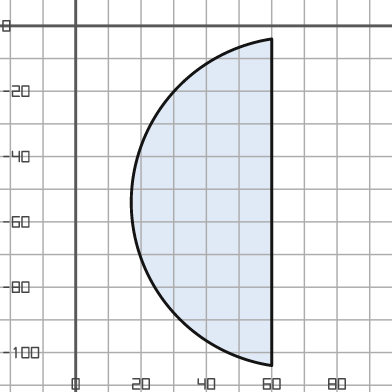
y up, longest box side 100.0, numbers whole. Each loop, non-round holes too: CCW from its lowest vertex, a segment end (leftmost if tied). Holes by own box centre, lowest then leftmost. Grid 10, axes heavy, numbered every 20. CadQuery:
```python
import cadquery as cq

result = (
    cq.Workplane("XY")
    .moveTo(60.0, -104.0)
    .lineTo(60.0, -4.0)
    .threePointArc((17.0, -54.0), (60.0, -104.0))
    .close()
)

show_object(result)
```